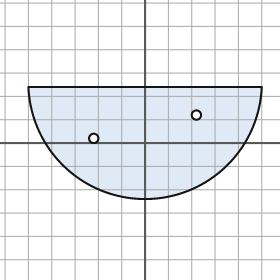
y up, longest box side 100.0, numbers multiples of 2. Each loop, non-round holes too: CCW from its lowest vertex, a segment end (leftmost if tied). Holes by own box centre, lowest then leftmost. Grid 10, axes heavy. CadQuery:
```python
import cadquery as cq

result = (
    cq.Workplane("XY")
    .moveTo(-50.0, 24.0)
    .threePointArc((0.0, -24.0), (50.0, 24.0))
    .close()
    .moveTo(-22.0, 2.0)
    .circle(2.0)
    .moveTo(22.0, 12.0)
    .circle(2.0)
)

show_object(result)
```